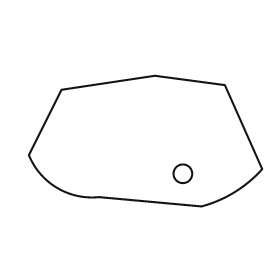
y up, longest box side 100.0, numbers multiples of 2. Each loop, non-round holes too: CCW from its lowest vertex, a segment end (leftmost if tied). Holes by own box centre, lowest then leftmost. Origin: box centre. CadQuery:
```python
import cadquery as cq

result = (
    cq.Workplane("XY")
    .moveTo(24.0, -28.0)
    .threePointArc((38.0, -22.0), (50.0, -12.0))
    .lineTo(34.0, 24.0)
    .lineTo(4.0, 28.0)
    .lineTo(-36.0, 22.0)
    .lineTo(-50.0, -6.0)
    .threePointArc((-38.0, -20.0), (-20.0, -24.0))
    .close()
    .moveTo(16.0, -14.0)
    .circle(4.0)
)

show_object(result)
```